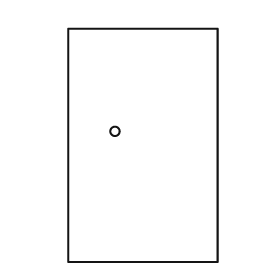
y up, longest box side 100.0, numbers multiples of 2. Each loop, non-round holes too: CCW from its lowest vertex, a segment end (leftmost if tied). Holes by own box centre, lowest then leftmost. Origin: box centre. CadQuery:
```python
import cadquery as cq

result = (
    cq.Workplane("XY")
    .moveTo(-32.0, -50.0)
    .lineTo(32.0, -50.0)
    .lineTo(32.0, 50.0)
    .lineTo(-32.0, 50.0)
    .close()
    .moveTo(-12.0, 6.0)
    .circle(2.0)
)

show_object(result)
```